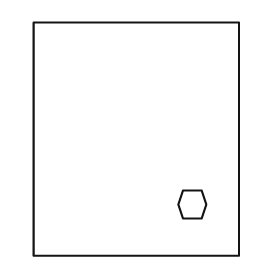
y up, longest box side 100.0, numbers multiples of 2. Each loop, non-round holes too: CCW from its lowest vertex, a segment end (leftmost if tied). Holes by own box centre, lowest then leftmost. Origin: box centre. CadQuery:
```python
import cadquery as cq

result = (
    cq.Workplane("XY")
    .moveTo(-44.0, -50.0)
    .lineTo(44.0, -50.0)
    .lineTo(44.0, 50.0)
    .lineTo(-44.0, 50.0)
    .close()
    .moveTo(20.0, -34.0)
    .lineTo(28.0, -34.0)
    .lineTo(30.0, -28.0)
    .lineTo(28.0, -22.0)
    .lineTo(20.0, -22.0)
    .lineTo(18.0, -28.0)
    .close()
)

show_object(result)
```